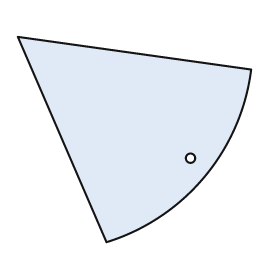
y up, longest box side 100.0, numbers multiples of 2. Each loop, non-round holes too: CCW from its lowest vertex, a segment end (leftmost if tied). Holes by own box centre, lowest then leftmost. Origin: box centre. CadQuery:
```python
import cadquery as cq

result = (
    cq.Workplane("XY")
    .moveTo(-12.0, -44.0)
    .threePointArc((30.0, -16.0), (50.0, 30.0))
    .lineTo(-50.0, 44.0)
    .close()
    .moveTo(24.0, -8.0)
    .circle(2.0)
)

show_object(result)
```